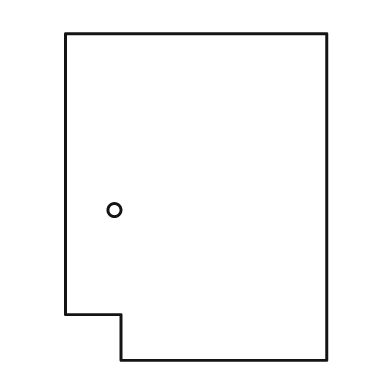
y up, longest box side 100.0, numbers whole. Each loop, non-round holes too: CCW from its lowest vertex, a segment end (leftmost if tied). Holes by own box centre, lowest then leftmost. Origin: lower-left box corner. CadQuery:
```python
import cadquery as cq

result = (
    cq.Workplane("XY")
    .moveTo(17.0, 0.0)
    .lineTo(80.0, 0.0)
    .lineTo(80.0, 100.0)
    .lineTo(0.0, 100.0)
    .lineTo(0.0, 14.0)
    .lineTo(17.0, 14.0)
    .close()
    .moveTo(15.0, 46.0)
    .circle(2.0)
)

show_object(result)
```